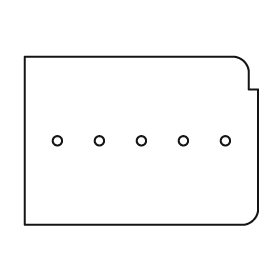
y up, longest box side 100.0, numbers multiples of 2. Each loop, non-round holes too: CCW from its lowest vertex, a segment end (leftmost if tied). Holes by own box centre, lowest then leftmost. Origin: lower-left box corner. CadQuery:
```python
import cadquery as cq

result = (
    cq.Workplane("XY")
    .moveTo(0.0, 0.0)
    .lineTo(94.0, 0.0)
    .threePointArc((98.0, 2.0), (100.0, 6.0))
    .lineTo(100.0, 58.0)
    .lineTo(96.0, 58.0)
    .lineTo(96.0, 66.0)
    .threePointArc((94.0, 70.0), (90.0, 72.0))
    .lineTo(0.0, 72.0)
    .close()
    .moveTo(14.0, 36.0)
    .circle(2.0)
    .moveTo(32.0, 36.0)
    .circle(2.0)
    .moveTo(50.0, 36.0)
    .circle(2.0)
    .moveTo(68.0, 36.0)
    .circle(2.0)
    .moveTo(86.0, 36.0)
    .circle(2.0)
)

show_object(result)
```